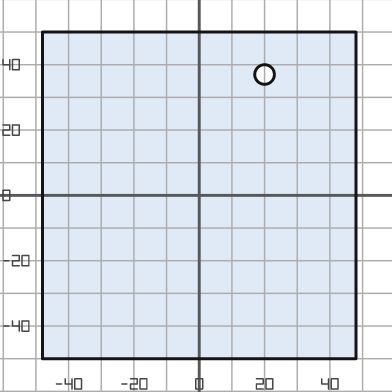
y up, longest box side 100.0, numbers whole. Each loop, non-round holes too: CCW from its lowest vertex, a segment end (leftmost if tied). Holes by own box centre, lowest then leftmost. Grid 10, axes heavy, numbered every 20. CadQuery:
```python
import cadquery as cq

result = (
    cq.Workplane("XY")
    .moveTo(-48.0, -50.0)
    .lineTo(48.0, -50.0)
    .lineTo(48.0, 50.0)
    .lineTo(-48.0, 50.0)
    .close()
    .moveTo(20.0, 37.0)
    .circle(3.0)
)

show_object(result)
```